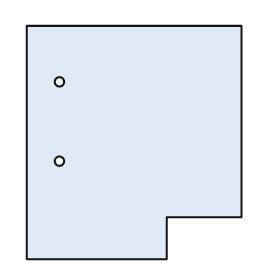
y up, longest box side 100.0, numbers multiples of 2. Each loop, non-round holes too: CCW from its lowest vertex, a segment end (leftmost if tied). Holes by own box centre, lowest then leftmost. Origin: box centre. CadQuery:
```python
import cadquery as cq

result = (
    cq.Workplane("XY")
    .moveTo(-46.0, -50.0)
    .lineTo(14.0, -50.0)
    .lineTo(14.0, -32.0)
    .lineTo(46.0, -32.0)
    .lineTo(46.0, 50.0)
    .lineTo(-46.0, 50.0)
    .close()
    .moveTo(-32.0, -8.0)
    .circle(2.0)
    .moveTo(-32.0, 26.0)
    .circle(2.0)
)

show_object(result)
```